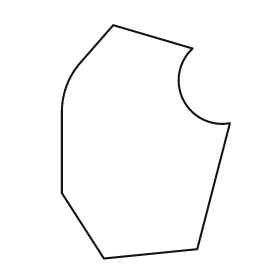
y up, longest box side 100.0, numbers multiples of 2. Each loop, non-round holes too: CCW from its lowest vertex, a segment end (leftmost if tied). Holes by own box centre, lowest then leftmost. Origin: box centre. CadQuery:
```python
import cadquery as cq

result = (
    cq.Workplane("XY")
    .moveTo(-18.0, -50.0)
    .lineTo(22.0, -46.0)
    .lineTo(36.0, 8.0)
    .threePointArc((16.0, 18.0), (20.0, 40.0))
    .lineTo(-14.0, 50.0)
    .lineTo(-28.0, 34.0)
    .threePointArc((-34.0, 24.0), (-36.0, 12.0))
    .lineTo(-36.0, -22.0)
    .close()
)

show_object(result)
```